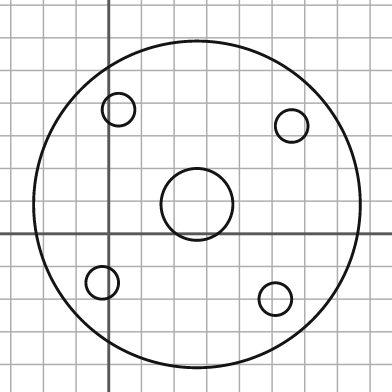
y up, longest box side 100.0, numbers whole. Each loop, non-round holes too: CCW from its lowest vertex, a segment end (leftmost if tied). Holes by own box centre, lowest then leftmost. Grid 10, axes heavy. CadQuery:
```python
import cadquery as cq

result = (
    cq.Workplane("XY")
    .moveTo(27.0, 9.0)
    .circle(50.0)
    .moveTo(51.0, -20.0)
    .circle(5.0)
    .moveTo(-2.0, -15.0)
    .circle(5.0)
    .moveTo(27.0, 9.0)
    .circle(11.0)
    .moveTo(56.0, 33.0)
    .circle(5.0)
    .moveTo(3.0, 38.0)
    .circle(5.0)
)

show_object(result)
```